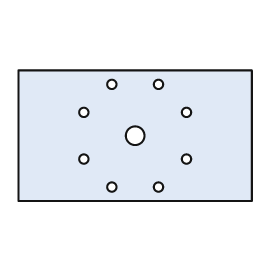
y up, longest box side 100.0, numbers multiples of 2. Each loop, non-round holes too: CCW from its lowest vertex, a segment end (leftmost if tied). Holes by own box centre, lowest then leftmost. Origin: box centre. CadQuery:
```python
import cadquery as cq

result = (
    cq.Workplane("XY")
    .moveTo(-50.0, -28.0)
    .lineTo(50.0, -28.0)
    .lineTo(50.0, 28.0)
    .lineTo(-50.0, 28.0)
    .close()
    .moveTo(-10.0, -22.0)
    .circle(2.0)
    .moveTo(10.0, -22.0)
    .circle(2.0)
    .moveTo(-22.0, -10.0)
    .circle(2.0)
    .moveTo(22.0, -10.0)
    .circle(2.0)
    .moveTo(0.0, 0.0)
    .circle(4.0)
    .moveTo(-22.0, 10.0)
    .circle(2.0)
    .moveTo(22.0, 10.0)
    .circle(2.0)
    .moveTo(-10.0, 22.0)
    .circle(2.0)
    .moveTo(10.0, 22.0)
    .circle(2.0)
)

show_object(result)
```